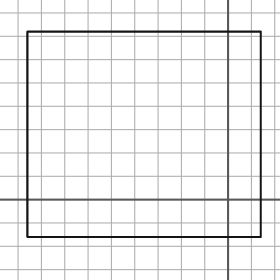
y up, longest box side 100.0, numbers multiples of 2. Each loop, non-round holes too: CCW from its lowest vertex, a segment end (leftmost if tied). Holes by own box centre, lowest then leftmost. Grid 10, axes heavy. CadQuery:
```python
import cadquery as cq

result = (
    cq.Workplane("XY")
    .moveTo(-86.0, -16.0)
    .lineTo(14.0, -16.0)
    .lineTo(14.0, 72.0)
    .lineTo(-86.0, 72.0)
    .close()
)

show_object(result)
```